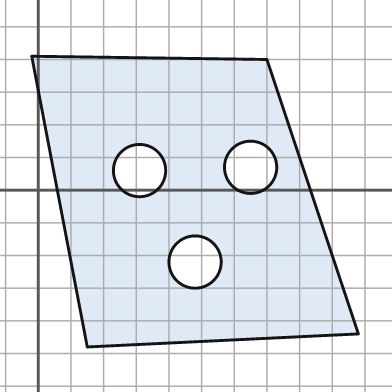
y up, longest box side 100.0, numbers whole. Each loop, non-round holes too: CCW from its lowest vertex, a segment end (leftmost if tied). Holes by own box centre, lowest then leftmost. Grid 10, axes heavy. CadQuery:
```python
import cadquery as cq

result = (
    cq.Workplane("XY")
    .moveTo(15.0, -48.0)
    .lineTo(98.0, -44.0)
    .lineTo(70.0, 40.0)
    .lineTo(-2.0, 41.0)
    .close()
    .moveTo(48.0, -22.0)
    .circle(8.0)
    .moveTo(31.0, 6.0)
    .circle(8.0)
    .moveTo(65.0, 7.0)
    .circle(8.0)
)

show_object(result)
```